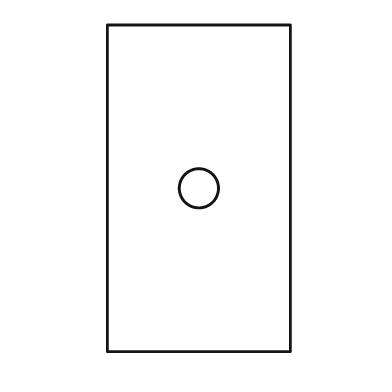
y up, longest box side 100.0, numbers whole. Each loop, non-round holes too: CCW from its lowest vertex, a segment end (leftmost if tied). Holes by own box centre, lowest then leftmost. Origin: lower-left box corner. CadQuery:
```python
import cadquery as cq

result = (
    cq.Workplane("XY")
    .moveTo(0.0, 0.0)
    .lineTo(56.0, 0.0)
    .lineTo(56.0, 100.0)
    .lineTo(0.0, 100.0)
    .close()
    .moveTo(28.0, 50.0)
    .circle(6.0)
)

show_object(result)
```